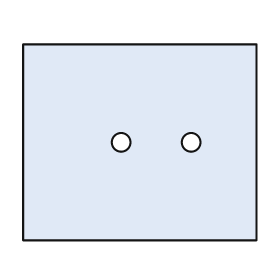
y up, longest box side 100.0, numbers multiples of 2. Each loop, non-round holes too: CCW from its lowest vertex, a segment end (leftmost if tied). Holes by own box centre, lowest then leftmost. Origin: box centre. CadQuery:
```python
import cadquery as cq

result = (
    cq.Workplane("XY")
    .moveTo(-50.0, -42.0)
    .lineTo(50.0, -42.0)
    .lineTo(50.0, 42.0)
    .lineTo(-50.0, 42.0)
    .close()
    .moveTo(-8.0, 0.0)
    .circle(4.0)
    .moveTo(22.0, 0.0)
    .circle(4.0)
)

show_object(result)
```